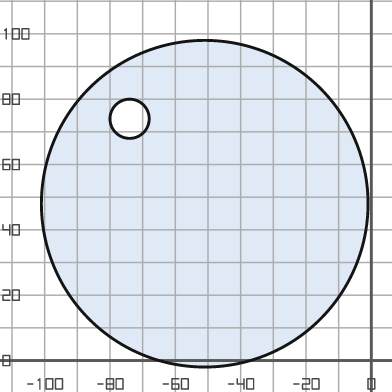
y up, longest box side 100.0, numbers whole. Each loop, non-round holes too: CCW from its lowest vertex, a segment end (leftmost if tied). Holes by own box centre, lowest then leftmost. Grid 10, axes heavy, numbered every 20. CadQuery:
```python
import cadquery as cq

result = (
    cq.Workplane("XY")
    .moveTo(-51.0, 48.0)
    .circle(50.0)
    .moveTo(-74.0, 74.0)
    .circle(6.0)
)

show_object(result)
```